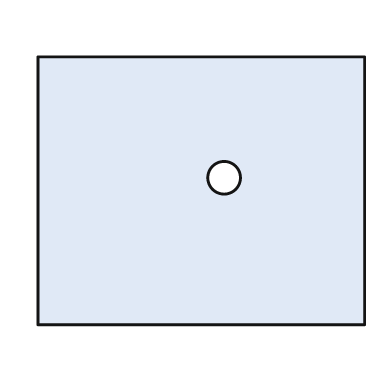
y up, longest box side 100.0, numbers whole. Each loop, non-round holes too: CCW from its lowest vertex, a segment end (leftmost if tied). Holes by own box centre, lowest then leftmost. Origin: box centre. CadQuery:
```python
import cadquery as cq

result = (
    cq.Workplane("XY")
    .moveTo(-50.0, -41.0)
    .lineTo(50.0, -41.0)
    .lineTo(50.0, 41.0)
    .lineTo(-50.0, 41.0)
    .close()
    .moveTo(7.0, 4.0)
    .circle(5.0)
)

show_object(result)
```